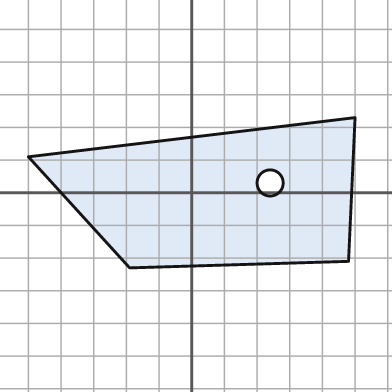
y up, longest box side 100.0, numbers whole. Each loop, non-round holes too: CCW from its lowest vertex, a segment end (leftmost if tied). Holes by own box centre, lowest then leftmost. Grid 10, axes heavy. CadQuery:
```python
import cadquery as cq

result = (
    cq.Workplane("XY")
    .moveTo(-19.0, -23.0)
    .lineTo(48.0, -21.0)
    .lineTo(50.0, 23.0)
    .lineTo(-50.0, 11.0)
    .close()
    .moveTo(24.0, 3.0)
    .circle(4.0)
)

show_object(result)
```